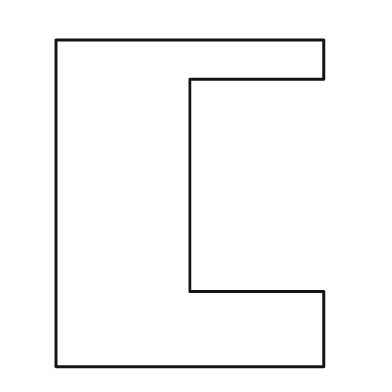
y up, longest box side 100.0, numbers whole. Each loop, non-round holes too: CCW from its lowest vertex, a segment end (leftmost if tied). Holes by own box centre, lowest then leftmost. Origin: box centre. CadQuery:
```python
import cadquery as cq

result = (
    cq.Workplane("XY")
    .moveTo(-41.0, -50.0)
    .lineTo(41.0, -50.0)
    .lineTo(41.0, -27.0)
    .lineTo(0.0, -27.0)
    .lineTo(0.0, 38.0)
    .lineTo(41.0, 38.0)
    .lineTo(41.0, 50.0)
    .lineTo(-41.0, 50.0)
    .close()
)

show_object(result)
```